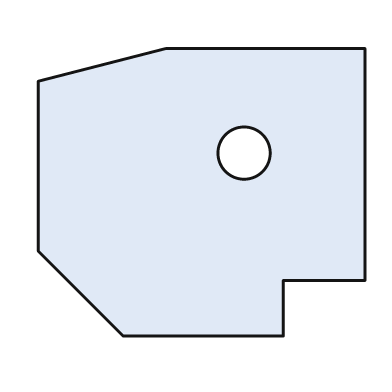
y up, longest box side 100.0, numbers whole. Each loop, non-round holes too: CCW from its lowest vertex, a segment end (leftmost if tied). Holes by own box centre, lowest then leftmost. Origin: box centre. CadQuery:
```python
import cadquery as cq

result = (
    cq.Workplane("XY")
    .moveTo(-24.0, -44.0)
    .lineTo(25.0, -44.0)
    .lineTo(25.0, -27.0)
    .lineTo(50.0, -27.0)
    .lineTo(50.0, 44.0)
    .lineTo(-11.0, 44.0)
    .lineTo(-50.0, 34.0)
    .lineTo(-50.0, -18.0)
    .close()
    .moveTo(13.0, 12.0)
    .circle(8.0)
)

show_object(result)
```